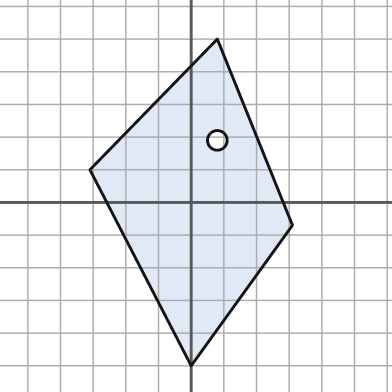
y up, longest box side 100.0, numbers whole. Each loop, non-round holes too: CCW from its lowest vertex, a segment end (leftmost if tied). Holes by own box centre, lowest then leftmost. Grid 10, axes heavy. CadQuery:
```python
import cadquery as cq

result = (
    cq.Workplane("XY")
    .moveTo(0.0, -50.0)
    .lineTo(31.0, -7.0)
    .lineTo(8.0, 50.0)
    .lineTo(-31.0, 10.0)
    .close()
    .moveTo(8.0, 19.0)
    .circle(3.0)
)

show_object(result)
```